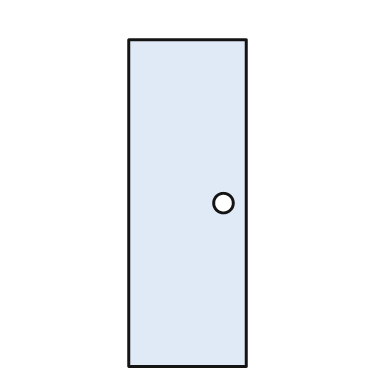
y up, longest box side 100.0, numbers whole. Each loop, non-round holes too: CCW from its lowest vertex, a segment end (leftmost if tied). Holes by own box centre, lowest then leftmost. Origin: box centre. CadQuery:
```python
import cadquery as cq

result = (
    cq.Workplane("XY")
    .moveTo(-18.0, -50.0)
    .lineTo(18.0, -50.0)
    .lineTo(18.0, 50.0)
    .lineTo(-18.0, 50.0)
    .close()
    .moveTo(11.0, 0.0)
    .circle(3.0)
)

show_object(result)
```